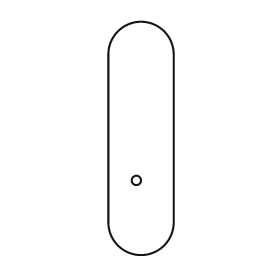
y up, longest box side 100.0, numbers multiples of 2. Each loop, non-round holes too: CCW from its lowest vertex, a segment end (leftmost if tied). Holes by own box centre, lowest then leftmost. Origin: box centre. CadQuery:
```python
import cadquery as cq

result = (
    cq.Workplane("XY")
    .moveTo(-14.0, -36.0)
    .threePointArc((0.0, -50.0), (14.0, -36.0))
    .lineTo(14.0, 36.0)
    .threePointArc((0.0, 50.0), (-14.0, 36.0))
    .close()
    .moveTo(-2.0, -18.0)
    .circle(2.0)
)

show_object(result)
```